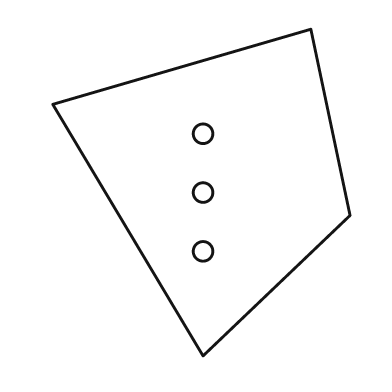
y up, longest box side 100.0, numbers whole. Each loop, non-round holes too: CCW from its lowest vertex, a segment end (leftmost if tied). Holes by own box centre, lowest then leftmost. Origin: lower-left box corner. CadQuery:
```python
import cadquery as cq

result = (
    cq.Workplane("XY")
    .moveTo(46.0, 0.0)
    .lineTo(91.0, 43.0)
    .lineTo(79.0, 100.0)
    .lineTo(0.0, 77.0)
    .close()
    .moveTo(46.0, 32.0)
    .circle(3.0)
    .moveTo(46.0, 50.0)
    .circle(3.0)
    .moveTo(46.0, 68.0)
    .circle(3.0)
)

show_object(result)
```